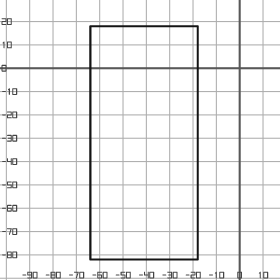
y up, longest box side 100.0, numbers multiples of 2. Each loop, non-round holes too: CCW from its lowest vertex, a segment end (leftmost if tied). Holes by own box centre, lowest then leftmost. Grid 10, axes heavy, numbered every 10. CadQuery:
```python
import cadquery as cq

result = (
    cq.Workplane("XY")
    .moveTo(-64.0, -82.0)
    .lineTo(-18.0, -82.0)
    .lineTo(-18.0, 18.0)
    .lineTo(-64.0, 18.0)
    .close()
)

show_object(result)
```